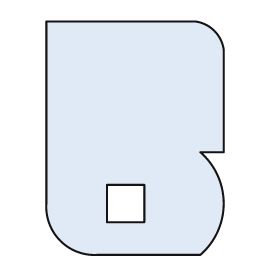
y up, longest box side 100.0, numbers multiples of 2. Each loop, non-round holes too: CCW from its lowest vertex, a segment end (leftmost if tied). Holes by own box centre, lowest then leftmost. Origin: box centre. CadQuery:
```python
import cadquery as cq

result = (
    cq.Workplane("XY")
    .moveTo(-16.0, -50.0)
    .lineTo(28.0, -50.0)
    .threePointArc((38.0, -28.0), (28.0, -6.0))
    .lineTo(38.0, -6.0)
    .lineTo(38.0, 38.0)
    .threePointArc((34.0, 46.0), (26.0, 50.0))
    .lineTo(-38.0, 50.0)
    .lineTo(-38.0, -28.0)
    .threePointArc((-32.0, -44.0), (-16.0, -50.0))
    .close()
    .moveTo(-12.0, -36.0)
    .lineTo(4.0, -36.0)
    .lineTo(4.0, -20.0)
    .lineTo(-12.0, -20.0)
    .close()
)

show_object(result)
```